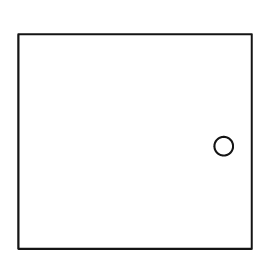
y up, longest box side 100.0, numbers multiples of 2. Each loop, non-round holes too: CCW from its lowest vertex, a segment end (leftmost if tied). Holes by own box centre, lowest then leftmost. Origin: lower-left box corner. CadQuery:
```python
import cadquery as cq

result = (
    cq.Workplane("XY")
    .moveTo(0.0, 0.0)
    .lineTo(100.0, 0.0)
    .lineTo(100.0, 92.0)
    .lineTo(0.0, 92.0)
    .close()
    .moveTo(88.0, 44.0)
    .circle(4.0)
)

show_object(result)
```